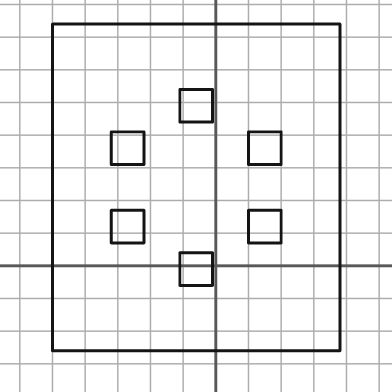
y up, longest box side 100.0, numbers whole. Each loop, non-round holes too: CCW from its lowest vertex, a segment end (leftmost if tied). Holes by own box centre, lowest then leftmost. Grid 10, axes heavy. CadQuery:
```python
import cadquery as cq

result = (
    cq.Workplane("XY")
    .moveTo(-50.0, -26.0)
    .lineTo(38.0, -26.0)
    .lineTo(38.0, 74.0)
    .lineTo(-50.0, 74.0)
    .close()
    .moveTo(-11.0, -6.0)
    .lineTo(-1.0, -6.0)
    .lineTo(-1.0, 4.0)
    .lineTo(-11.0, 4.0)
    .close()
    .moveTo(-32.0, 7.0)
    .lineTo(-22.0, 7.0)
    .lineTo(-22.0, 17.0)
    .lineTo(-32.0, 17.0)
    .close()
    .moveTo(10.0, 7.0)
    .lineTo(20.0, 7.0)
    .lineTo(20.0, 17.0)
    .lineTo(10.0, 17.0)
    .close()
    .moveTo(-32.0, 31.0)
    .lineTo(-22.0, 31.0)
    .lineTo(-22.0, 41.0)
    .lineTo(-32.0, 41.0)
    .close()
    .moveTo(10.0, 31.0)
    .lineTo(20.0, 31.0)
    .lineTo(20.0, 41.0)
    .lineTo(10.0, 41.0)
    .close()
    .moveTo(-11.0, 44.0)
    .lineTo(-1.0, 44.0)
    .lineTo(-1.0, 54.0)
    .lineTo(-11.0, 54.0)
    .close()
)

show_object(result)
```